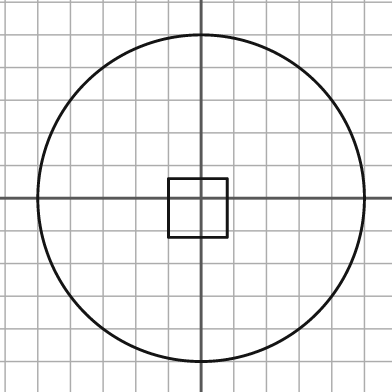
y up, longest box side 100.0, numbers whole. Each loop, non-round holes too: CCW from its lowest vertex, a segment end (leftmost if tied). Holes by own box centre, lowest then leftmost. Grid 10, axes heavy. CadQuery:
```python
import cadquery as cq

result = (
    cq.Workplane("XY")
    .moveTo(0.0, 0.0)
    .circle(50.0)
    .moveTo(-10.0, -12.0)
    .lineTo(8.0, -12.0)
    .lineTo(8.0, 6.0)
    .lineTo(-10.0, 6.0)
    .close()
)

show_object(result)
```